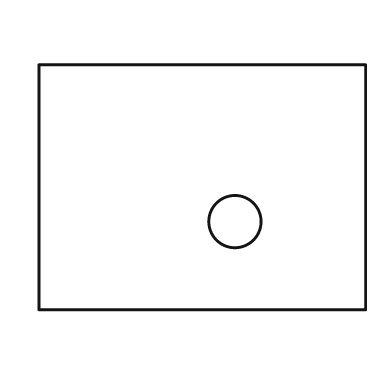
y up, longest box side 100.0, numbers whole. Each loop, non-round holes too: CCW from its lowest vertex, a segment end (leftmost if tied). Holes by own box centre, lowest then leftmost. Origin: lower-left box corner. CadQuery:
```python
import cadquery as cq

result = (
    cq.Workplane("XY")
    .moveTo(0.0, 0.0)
    .lineTo(100.0, 0.0)
    .lineTo(100.0, 75.0)
    .lineTo(0.0, 75.0)
    .close()
    .moveTo(60.0, 27.0)
    .circle(8.0)
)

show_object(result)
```